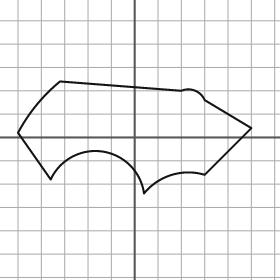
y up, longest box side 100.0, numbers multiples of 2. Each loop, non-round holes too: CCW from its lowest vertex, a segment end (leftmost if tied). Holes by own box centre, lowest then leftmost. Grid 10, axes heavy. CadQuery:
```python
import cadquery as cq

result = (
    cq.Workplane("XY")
    .moveTo(4.0, -24.0)
    .threePointArc((16.0, -16.0), (30.0, -16.0))
    .lineTo(50.0, 4.0)
    .lineTo(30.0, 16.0)
    .threePointArc((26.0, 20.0), (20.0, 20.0))
    .lineTo(-32.0, 24.0)
    .threePointArc((-42.0, 14.0), (-50.0, 2.0))
    .lineTo(-36.0, -18.0)
    .threePointArc((-14.0, -6.0), (4.0, -24.0))
    .close()
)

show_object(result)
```